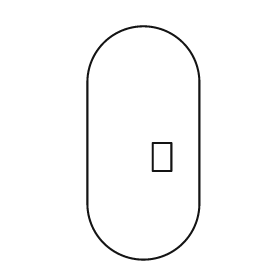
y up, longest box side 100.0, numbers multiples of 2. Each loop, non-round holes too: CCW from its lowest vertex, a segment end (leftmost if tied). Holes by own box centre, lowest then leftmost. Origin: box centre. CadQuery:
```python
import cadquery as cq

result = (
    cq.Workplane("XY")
    .moveTo(-24.0, -26.0)
    .threePointArc((0.0, -50.0), (24.0, -26.0))
    .lineTo(24.0, 26.0)
    .threePointArc((0.0, 50.0), (-24.0, 26.0))
    .close()
    .moveTo(4.0, -12.0)
    .lineTo(12.0, -12.0)
    .lineTo(12.0, 0.0)
    .lineTo(4.0, 0.0)
    .close()
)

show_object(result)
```